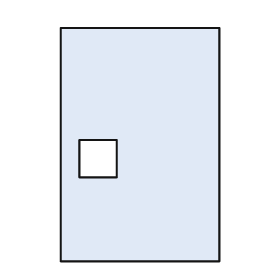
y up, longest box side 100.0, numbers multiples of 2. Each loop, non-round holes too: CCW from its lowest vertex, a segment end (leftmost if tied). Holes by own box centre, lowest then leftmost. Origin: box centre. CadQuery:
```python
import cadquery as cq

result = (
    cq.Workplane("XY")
    .moveTo(-34.0, -50.0)
    .lineTo(34.0, -50.0)
    .lineTo(34.0, 50.0)
    .lineTo(-34.0, 50.0)
    .close()
    .moveTo(-26.0, -14.0)
    .lineTo(-10.0, -14.0)
    .lineTo(-10.0, 2.0)
    .lineTo(-26.0, 2.0)
    .close()
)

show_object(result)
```